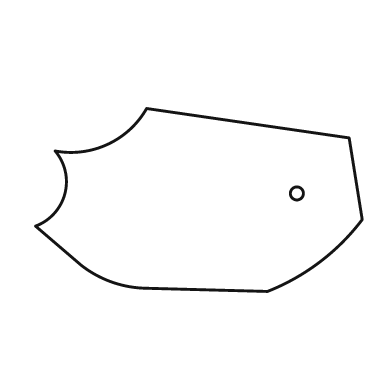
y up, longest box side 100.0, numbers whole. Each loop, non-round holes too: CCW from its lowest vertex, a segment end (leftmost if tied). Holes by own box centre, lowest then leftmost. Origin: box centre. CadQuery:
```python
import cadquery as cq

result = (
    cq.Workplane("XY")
    .moveTo(21.0, -28.0)
    .threePointArc((37.0, -19.0), (50.0, -6.0))
    .lineTo(46.0, 19.0)
    .lineTo(-16.0, 28.0)
    .threePointArc((-28.0, 17.0), (-44.0, 15.0))
    .threePointArc((-41.0, 2.0), (-50.0, -8.0))
    .lineTo(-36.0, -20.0)
    .threePointArc((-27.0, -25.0), (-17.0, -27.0))
    .close()
    .moveTo(30.0, 2.0)
    .circle(2.0)
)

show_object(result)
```